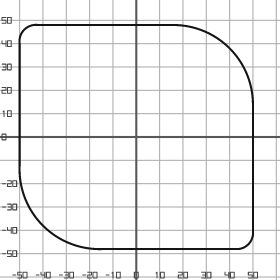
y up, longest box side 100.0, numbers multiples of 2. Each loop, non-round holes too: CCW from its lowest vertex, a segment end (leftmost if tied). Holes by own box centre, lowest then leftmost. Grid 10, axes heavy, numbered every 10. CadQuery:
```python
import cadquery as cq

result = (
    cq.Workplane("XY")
    .moveTo(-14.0, -48.0)
    .lineTo(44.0, -48.0)
    .threePointArc((48.0, -46.0), (50.0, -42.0))
    .lineTo(50.0, 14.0)
    .threePointArc((40.0, 38.0), (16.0, 48.0))
    .lineTo(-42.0, 48.0)
    .threePointArc((-48.0, 46.0), (-50.0, 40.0))
    .lineTo(-50.0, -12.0)
    .threePointArc((-40.0, -38.0), (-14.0, -48.0))
    .close()
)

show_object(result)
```